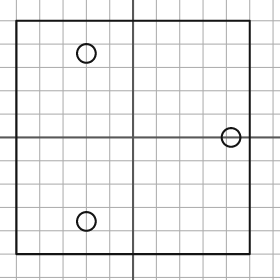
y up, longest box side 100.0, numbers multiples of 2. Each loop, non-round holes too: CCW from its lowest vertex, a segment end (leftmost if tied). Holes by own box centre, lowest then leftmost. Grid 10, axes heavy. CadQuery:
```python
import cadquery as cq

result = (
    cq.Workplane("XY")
    .moveTo(-50.0, -50.0)
    .lineTo(50.0, -50.0)
    .lineTo(50.0, 50.0)
    .lineTo(-50.0, 50.0)
    .close()
    .moveTo(-20.0, -36.0)
    .circle(4.0)
    .moveTo(42.0, 0.0)
    .circle(4.0)
    .moveTo(-20.0, 36.0)
    .circle(4.0)
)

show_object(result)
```